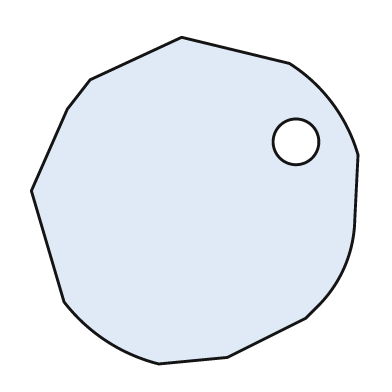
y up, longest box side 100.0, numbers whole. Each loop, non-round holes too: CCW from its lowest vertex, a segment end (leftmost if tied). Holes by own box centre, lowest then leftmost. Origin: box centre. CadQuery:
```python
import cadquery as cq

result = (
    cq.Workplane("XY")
    .moveTo(-11.0, -50.0)
    .lineTo(10.0, -48.0)
    .lineTo(34.0, -36.0)
    .lineTo(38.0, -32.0)
    .threePointArc((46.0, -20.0), (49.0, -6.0))
    .lineTo(50.0, 14.0)
    .threePointArc((42.0, 30.0), (29.0, 42.0))
    .lineTo(-4.0, 50.0)
    .lineTo(-32.0, 37.0)
    .lineTo(-39.0, 28.0)
    .lineTo(-50.0, 3.0)
    .lineTo(-40.0, -31.0)
    .threePointArc((-27.0, -43.0), (-11.0, -50.0))
    .close()
    .moveTo(31.0, 18.0)
    .circle(7.0)
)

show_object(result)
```